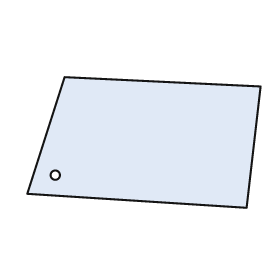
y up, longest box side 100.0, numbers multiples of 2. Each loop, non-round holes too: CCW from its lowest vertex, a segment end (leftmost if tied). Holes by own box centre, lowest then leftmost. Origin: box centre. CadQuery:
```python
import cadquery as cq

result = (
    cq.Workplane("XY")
    .moveTo(44.0, -28.0)
    .lineTo(50.0, 24.0)
    .lineTo(-34.0, 28.0)
    .lineTo(-50.0, -22.0)
    .close()
    .moveTo(-38.0, -14.0)
    .circle(2.0)
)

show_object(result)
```